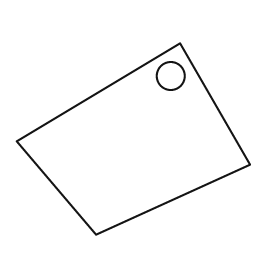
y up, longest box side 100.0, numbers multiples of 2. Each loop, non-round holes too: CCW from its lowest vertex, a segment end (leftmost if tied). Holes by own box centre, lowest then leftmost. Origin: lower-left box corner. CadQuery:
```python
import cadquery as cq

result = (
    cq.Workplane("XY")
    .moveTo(34.0, 0.0)
    .lineTo(100.0, 30.0)
    .lineTo(70.0, 82.0)
    .lineTo(0.0, 40.0)
    .close()
    .moveTo(66.0, 68.0)
    .circle(6.0)
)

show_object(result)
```